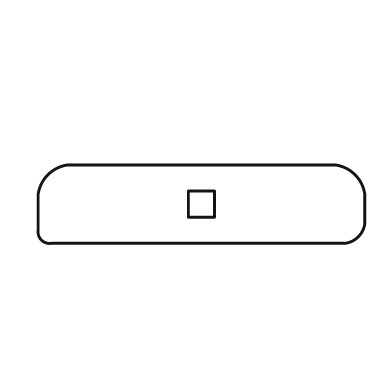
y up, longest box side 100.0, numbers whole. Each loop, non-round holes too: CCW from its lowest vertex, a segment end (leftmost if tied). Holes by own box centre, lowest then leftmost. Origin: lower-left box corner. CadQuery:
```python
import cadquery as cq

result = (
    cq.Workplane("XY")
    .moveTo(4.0, 0.0)
    .lineTo(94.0, 0.0)
    .threePointArc((98.0, 2.0), (100.0, 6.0))
    .lineTo(100.0, 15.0)
    .threePointArc((97.0, 21.0), (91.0, 24.0))
    .lineTo(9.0, 24.0)
    .threePointArc((3.0, 21.0), (0.0, 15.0))
    .lineTo(0.0, 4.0)
    .threePointArc((1.0, 1.0), (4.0, 0.0))
    .close()
    .moveTo(46.0, 8.0)
    .lineTo(54.0, 8.0)
    .lineTo(54.0, 16.0)
    .lineTo(46.0, 16.0)
    .close()
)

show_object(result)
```